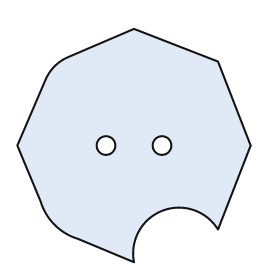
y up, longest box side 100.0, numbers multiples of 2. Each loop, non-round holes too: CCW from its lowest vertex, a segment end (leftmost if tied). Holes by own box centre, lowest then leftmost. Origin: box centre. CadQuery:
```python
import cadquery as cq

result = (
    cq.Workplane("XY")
    .moveTo(0.0, -50.0)
    .threePointArc((12.0, -28.0), (36.0, -36.0))
    .lineTo(50.0, 0.0)
    .lineTo(36.0, 36.0)
    .lineTo(0.0, 50.0)
    .lineTo(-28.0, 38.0)
    .threePointArc((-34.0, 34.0), (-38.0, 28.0))
    .lineTo(-50.0, 0.0)
    .lineTo(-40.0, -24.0)
    .threePointArc((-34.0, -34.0), (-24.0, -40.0))
    .close()
    .moveTo(-12.0, 0.0)
    .circle(4.0)
    .moveTo(12.0, 0.0)
    .circle(4.0)
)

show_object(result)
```